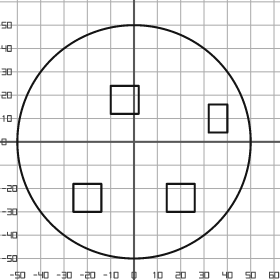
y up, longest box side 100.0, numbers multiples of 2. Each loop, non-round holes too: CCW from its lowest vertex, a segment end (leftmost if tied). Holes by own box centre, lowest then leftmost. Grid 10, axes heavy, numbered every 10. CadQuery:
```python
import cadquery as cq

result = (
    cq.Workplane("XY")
    .moveTo(0.0, 0.0)
    .circle(50.0)
    .moveTo(-26.0, -30.0)
    .lineTo(-14.0, -30.0)
    .lineTo(-14.0, -18.0)
    .lineTo(-26.0, -18.0)
    .close()
    .moveTo(14.0, -30.0)
    .lineTo(26.0, -30.0)
    .lineTo(26.0, -18.0)
    .lineTo(14.0, -18.0)
    .close()
    .moveTo(32.0, 4.0)
    .lineTo(40.0, 4.0)
    .lineTo(40.0, 16.0)
    .lineTo(32.0, 16.0)
    .close()
    .moveTo(-10.0, 12.0)
    .lineTo(2.0, 12.0)
    .lineTo(2.0, 24.0)
    .lineTo(-10.0, 24.0)
    .close()
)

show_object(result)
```